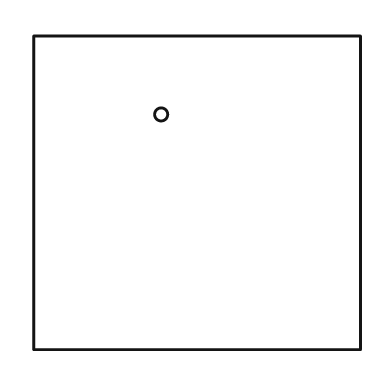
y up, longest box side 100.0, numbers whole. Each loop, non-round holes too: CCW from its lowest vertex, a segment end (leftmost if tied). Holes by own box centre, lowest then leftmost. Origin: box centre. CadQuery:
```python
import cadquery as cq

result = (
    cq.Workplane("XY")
    .moveTo(-50.0, -48.0)
    .lineTo(50.0, -48.0)
    .lineTo(50.0, 48.0)
    .lineTo(-50.0, 48.0)
    .close()
    .moveTo(-11.0, 24.0)
    .circle(2.0)
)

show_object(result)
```